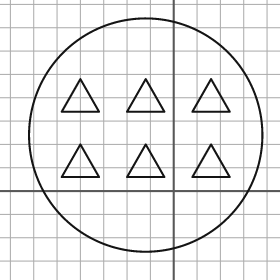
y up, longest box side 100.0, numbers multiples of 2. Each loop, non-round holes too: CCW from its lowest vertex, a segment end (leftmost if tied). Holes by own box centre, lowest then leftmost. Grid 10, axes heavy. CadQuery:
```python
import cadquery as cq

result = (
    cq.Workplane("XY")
    .moveTo(-12.0, 24.0)
    .circle(50.0)
    .moveTo(-48.0, 6.0)
    .lineTo(-32.0, 6.0)
    .lineTo(-40.0, 20.0)
    .close()
    .moveTo(-20.0, 6.0)
    .lineTo(-4.0, 6.0)
    .lineTo(-12.0, 20.0)
    .close()
    .moveTo(8.0, 6.0)
    .lineTo(24.0, 6.0)
    .lineTo(16.0, 20.0)
    .close()
    .moveTo(-48.0, 34.0)
    .lineTo(-32.0, 34.0)
    .lineTo(-40.0, 48.0)
    .close()
    .moveTo(-20.0, 34.0)
    .lineTo(-4.0, 34.0)
    .lineTo(-12.0, 48.0)
    .close()
    .moveTo(8.0, 34.0)
    .lineTo(24.0, 34.0)
    .lineTo(16.0, 48.0)
    .close()
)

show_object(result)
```